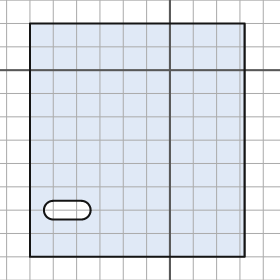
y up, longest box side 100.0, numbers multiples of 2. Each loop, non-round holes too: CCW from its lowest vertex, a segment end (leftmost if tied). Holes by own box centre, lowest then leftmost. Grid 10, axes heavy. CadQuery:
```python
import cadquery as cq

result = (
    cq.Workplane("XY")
    .moveTo(-60.0, -80.0)
    .lineTo(32.0, -80.0)
    .lineTo(32.0, 20.0)
    .lineTo(-60.0, 20.0)
    .close()
    .moveTo(-50.0, -64.0)
    .lineTo(-38.0, -64.0)
    .threePointArc((-34.0, -60.0), (-38.0, -56.0))
    .lineTo(-50.0, -56.0)
    .threePointArc((-54.0, -60.0), (-50.0, -64.0))
    .close()
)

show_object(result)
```